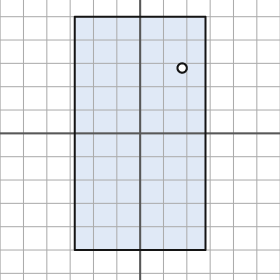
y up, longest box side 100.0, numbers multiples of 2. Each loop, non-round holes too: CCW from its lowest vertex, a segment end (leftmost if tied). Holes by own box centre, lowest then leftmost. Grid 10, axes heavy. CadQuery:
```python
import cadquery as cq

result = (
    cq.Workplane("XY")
    .moveTo(-28.0, -50.0)
    .lineTo(28.0, -50.0)
    .lineTo(28.0, 50.0)
    .lineTo(-28.0, 50.0)
    .close()
    .moveTo(18.0, 28.0)
    .circle(2.0)
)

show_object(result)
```